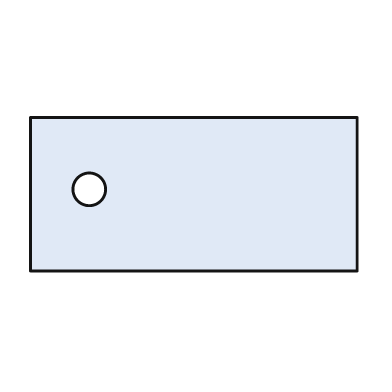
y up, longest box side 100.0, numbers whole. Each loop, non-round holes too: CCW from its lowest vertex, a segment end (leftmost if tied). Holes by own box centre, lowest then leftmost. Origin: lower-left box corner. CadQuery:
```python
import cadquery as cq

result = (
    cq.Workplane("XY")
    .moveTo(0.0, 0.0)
    .lineTo(100.0, 0.0)
    .lineTo(100.0, 47.0)
    .lineTo(0.0, 47.0)
    .close()
    .moveTo(18.0, 25.0)
    .circle(5.0)
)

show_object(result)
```